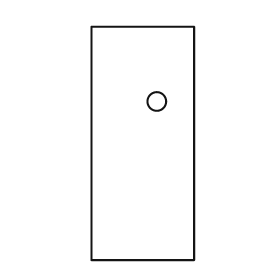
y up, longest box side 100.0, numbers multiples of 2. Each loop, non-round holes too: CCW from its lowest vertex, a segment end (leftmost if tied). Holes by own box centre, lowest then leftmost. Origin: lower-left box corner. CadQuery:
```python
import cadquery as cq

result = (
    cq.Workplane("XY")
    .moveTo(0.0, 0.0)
    .lineTo(44.0, 0.0)
    .lineTo(44.0, 100.0)
    .lineTo(0.0, 100.0)
    .close()
    .moveTo(28.0, 68.0)
    .circle(4.0)
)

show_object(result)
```